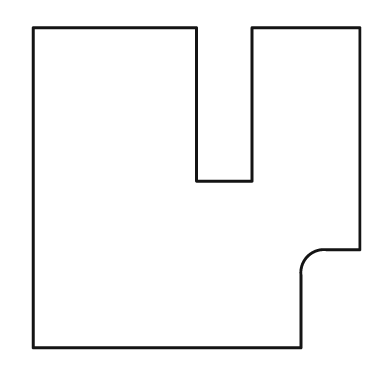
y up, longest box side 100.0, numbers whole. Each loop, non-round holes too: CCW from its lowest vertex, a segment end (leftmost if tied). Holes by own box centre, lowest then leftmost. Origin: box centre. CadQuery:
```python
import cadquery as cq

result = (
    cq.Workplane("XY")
    .moveTo(-50.0, -49.0)
    .lineTo(32.0, -49.0)
    .lineTo(32.0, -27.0)
    .threePointArc((34.0, -21.0), (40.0, -19.0))
    .lineTo(50.0, -19.0)
    .lineTo(50.0, 49.0)
    .lineTo(17.0, 49.0)
    .lineTo(17.0, 2.0)
    .lineTo(0.0, 2.0)
    .lineTo(0.0, 49.0)
    .lineTo(-50.0, 49.0)
    .close()
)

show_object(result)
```